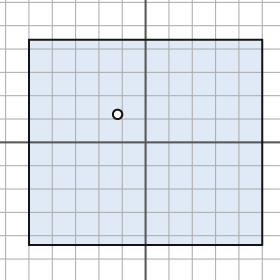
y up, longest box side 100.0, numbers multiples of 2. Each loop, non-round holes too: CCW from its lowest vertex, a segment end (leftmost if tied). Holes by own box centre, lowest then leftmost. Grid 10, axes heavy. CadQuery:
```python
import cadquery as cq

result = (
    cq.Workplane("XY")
    .moveTo(-50.0, -44.0)
    .lineTo(50.0, -44.0)
    .lineTo(50.0, 44.0)
    .lineTo(-50.0, 44.0)
    .close()
    .moveTo(-12.0, 12.0)
    .circle(2.0)
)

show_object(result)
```